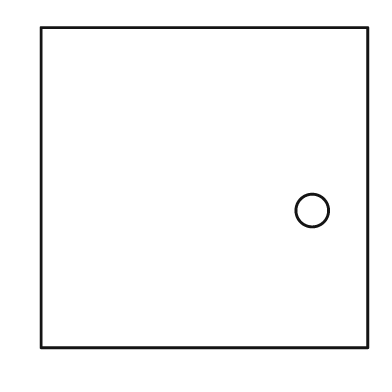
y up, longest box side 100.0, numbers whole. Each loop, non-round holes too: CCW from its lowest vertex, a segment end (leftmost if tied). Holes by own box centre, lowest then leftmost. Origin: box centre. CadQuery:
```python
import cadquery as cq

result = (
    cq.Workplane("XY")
    .moveTo(-50.0, -49.0)
    .lineTo(50.0, -49.0)
    .lineTo(50.0, 49.0)
    .lineTo(-50.0, 49.0)
    .close()
    .moveTo(33.0, -7.0)
    .circle(5.0)
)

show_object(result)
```